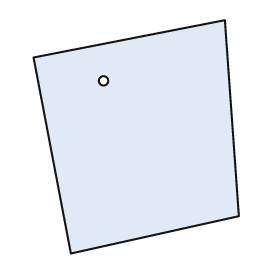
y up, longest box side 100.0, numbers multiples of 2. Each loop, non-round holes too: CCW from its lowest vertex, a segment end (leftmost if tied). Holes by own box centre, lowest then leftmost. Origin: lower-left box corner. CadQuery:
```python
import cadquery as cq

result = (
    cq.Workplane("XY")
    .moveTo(16.0, 0.0)
    .lineTo(88.0, 16.0)
    .lineTo(82.0, 100.0)
    .lineTo(0.0, 84.0)
    .close()
    .moveTo(30.0, 74.0)
    .circle(2.0)
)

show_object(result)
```